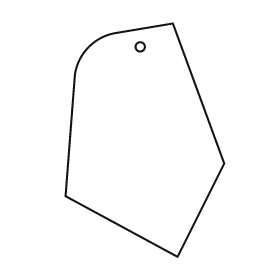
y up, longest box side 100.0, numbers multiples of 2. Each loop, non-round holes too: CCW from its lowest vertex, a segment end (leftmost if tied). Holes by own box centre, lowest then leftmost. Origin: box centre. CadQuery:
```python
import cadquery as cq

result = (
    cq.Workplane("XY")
    .moveTo(14.0, -50.0)
    .lineTo(34.0, -10.0)
    .lineTo(12.0, 50.0)
    .lineTo(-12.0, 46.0)
    .threePointArc((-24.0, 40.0), (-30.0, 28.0))
    .lineTo(-34.0, -24.0)
    .close()
    .moveTo(-2.0, 40.0)
    .circle(2.0)
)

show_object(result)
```